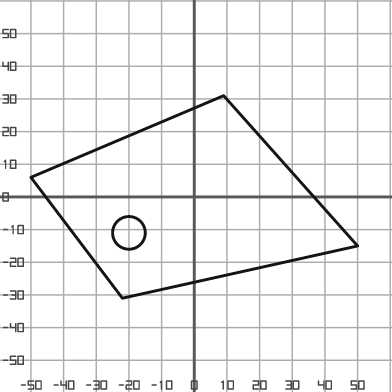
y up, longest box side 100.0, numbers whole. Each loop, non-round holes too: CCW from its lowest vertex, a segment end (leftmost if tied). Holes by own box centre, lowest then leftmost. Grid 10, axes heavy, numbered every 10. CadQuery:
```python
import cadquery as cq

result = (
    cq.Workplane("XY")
    .moveTo(-22.0, -31.0)
    .lineTo(50.0, -15.0)
    .lineTo(9.0, 31.0)
    .lineTo(-50.0, 6.0)
    .close()
    .moveTo(-20.0, -11.0)
    .circle(5.0)
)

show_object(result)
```